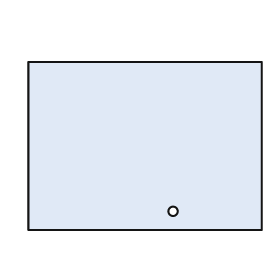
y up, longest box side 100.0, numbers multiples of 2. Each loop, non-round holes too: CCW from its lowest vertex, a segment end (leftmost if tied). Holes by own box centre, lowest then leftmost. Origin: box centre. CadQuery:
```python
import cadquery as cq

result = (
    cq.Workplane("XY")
    .moveTo(-50.0, -36.0)
    .lineTo(50.0, -36.0)
    .lineTo(50.0, 36.0)
    .lineTo(-50.0, 36.0)
    .close()
    .moveTo(12.0, -28.0)
    .circle(2.0)
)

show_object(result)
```